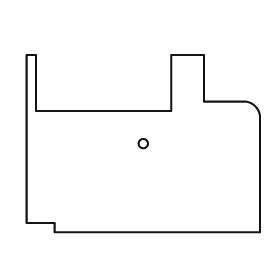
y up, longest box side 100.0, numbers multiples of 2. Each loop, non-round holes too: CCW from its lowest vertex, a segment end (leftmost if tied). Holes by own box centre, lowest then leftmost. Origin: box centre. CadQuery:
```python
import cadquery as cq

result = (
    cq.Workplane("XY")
    .moveTo(-38.0, -38.0)
    .lineTo(50.0, -38.0)
    .lineTo(50.0, 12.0)
    .threePointArc((48.0, 16.0), (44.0, 18.0))
    .lineTo(26.0, 18.0)
    .lineTo(26.0, 38.0)
    .lineTo(12.0, 38.0)
    .lineTo(12.0, 14.0)
    .lineTo(-46.0, 14.0)
    .lineTo(-46.0, 38.0)
    .lineTo(-50.0, 38.0)
    .lineTo(-50.0, -34.0)
    .lineTo(-38.0, -34.0)
    .close()
    .moveTo(0.0, 0.0)
    .circle(2.0)
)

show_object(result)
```